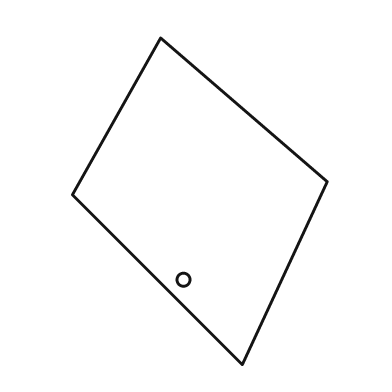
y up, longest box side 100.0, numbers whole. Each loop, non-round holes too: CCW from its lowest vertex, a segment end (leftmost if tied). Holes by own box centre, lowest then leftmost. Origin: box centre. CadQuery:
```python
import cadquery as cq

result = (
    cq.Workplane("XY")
    .moveTo(13.0, -50.0)
    .lineTo(39.0, 6.0)
    .lineTo(-12.0, 50.0)
    .lineTo(-39.0, 2.0)
    .close()
    .moveTo(-5.0, -24.0)
    .circle(2.0)
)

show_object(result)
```